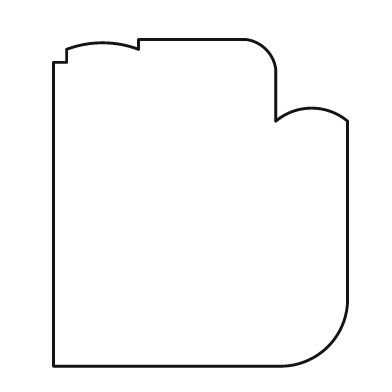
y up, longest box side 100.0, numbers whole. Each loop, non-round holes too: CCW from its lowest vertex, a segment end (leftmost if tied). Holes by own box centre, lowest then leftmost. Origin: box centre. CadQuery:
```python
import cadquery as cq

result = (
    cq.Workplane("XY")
    .moveTo(-45.0, -50.0)
    .lineTo(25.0, -50.0)
    .threePointArc((39.0, -44.0), (45.0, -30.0))
    .lineTo(45.0, 25.0)
    .threePointArc((34.0, 29.0), (23.0, 25.0))
    .lineTo(23.0, 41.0)
    .threePointArc((20.0, 47.0), (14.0, 50.0))
    .lineTo(-19.0, 50.0)
    .lineTo(-19.0, 47.0)
    .threePointArc((-30.0, 49.0), (-41.0, 47.0))
    .lineTo(-41.0, 43.0)
    .lineTo(-45.0, 43.0)
    .close()
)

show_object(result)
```